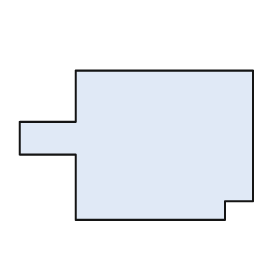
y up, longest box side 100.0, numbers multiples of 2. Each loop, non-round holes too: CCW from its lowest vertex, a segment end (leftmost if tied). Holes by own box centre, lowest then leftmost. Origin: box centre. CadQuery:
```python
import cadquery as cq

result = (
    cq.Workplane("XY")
    .moveTo(-26.0, -32.0)
    .lineTo(38.0, -32.0)
    .lineTo(38.0, -24.0)
    .lineTo(50.0, -24.0)
    .lineTo(50.0, 32.0)
    .lineTo(-26.0, 32.0)
    .lineTo(-26.0, 10.0)
    .lineTo(-50.0, 10.0)
    .lineTo(-50.0, -4.0)
    .lineTo(-26.0, -4.0)
    .close()
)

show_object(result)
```